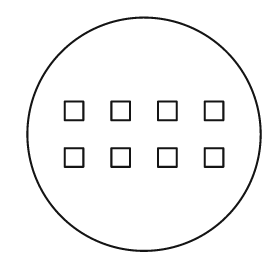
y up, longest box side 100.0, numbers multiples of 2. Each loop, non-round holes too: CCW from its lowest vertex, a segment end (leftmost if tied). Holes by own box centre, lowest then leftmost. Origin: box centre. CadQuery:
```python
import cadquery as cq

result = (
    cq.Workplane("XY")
    .moveTo(0.0, 0.0)
    .circle(50.0)
    .moveTo(-34.0, -14.0)
    .lineTo(-26.0, -14.0)
    .lineTo(-26.0, -6.0)
    .lineTo(-34.0, -6.0)
    .close()
    .moveTo(-14.0, -14.0)
    .lineTo(-6.0, -14.0)
    .lineTo(-6.0, -6.0)
    .lineTo(-14.0, -6.0)
    .close()
    .moveTo(6.0, -14.0)
    .lineTo(14.0, -14.0)
    .lineTo(14.0, -6.0)
    .lineTo(6.0, -6.0)
    .close()
    .moveTo(26.0, -14.0)
    .lineTo(34.0, -14.0)
    .lineTo(34.0, -6.0)
    .lineTo(26.0, -6.0)
    .close()
    .moveTo(-34.0, 6.0)
    .lineTo(-26.0, 6.0)
    .lineTo(-26.0, 14.0)
    .lineTo(-34.0, 14.0)
    .close()
    .moveTo(-14.0, 6.0)
    .lineTo(-6.0, 6.0)
    .lineTo(-6.0, 14.0)
    .lineTo(-14.0, 14.0)
    .close()
    .moveTo(6.0, 6.0)
    .lineTo(14.0, 6.0)
    .lineTo(14.0, 14.0)
    .lineTo(6.0, 14.0)
    .close()
    .moveTo(26.0, 6.0)
    .lineTo(34.0, 6.0)
    .lineTo(34.0, 14.0)
    .lineTo(26.0, 14.0)
    .close()
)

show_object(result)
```